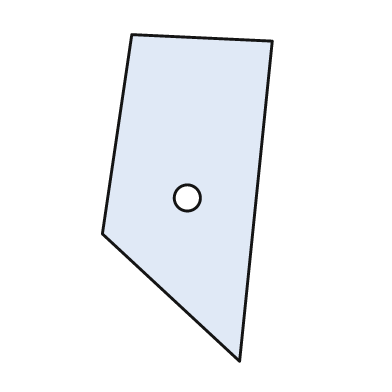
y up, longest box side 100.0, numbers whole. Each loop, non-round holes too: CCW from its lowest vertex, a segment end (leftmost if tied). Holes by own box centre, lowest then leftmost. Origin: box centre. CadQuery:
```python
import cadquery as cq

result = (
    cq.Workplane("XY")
    .moveTo(16.0, -50.0)
    .lineTo(26.0, 48.0)
    .lineTo(-17.0, 50.0)
    .lineTo(-26.0, -11.0)
    .close()
    .moveTo(0.0, 0.0)
    .circle(4.0)
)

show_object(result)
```